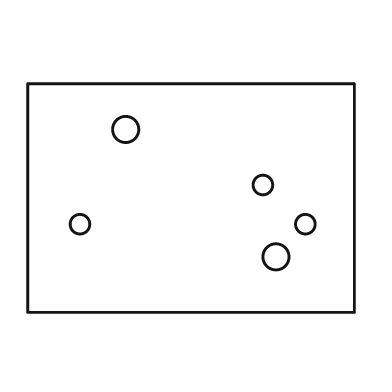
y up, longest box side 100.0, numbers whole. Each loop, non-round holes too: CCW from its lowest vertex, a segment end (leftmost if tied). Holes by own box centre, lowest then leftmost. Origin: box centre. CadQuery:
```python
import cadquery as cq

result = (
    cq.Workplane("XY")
    .moveTo(-50.0, -35.0)
    .lineTo(50.0, -35.0)
    .lineTo(50.0, 35.0)
    .lineTo(-50.0, 35.0)
    .close()
    .moveTo(26.0, -18.0)
    .circle(4.0)
    .moveTo(-34.0, -8.0)
    .circle(3.0)
    .moveTo(35.0, -8.0)
    .circle(3.0)
    .moveTo(22.0, 4.0)
    .circle(3.0)
    .moveTo(-20.0, 21.0)
    .circle(4.0)
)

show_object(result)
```